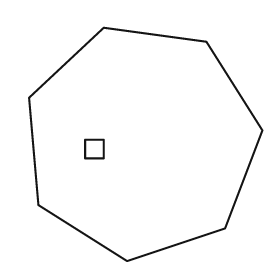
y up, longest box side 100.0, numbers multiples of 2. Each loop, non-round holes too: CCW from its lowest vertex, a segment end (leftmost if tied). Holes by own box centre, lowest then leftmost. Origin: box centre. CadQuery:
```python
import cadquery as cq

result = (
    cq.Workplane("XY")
    .moveTo(-8.0, -50.0)
    .lineTo(34.0, -36.0)
    .lineTo(50.0, 6.0)
    .lineTo(26.0, 44.0)
    .lineTo(-18.0, 50.0)
    .lineTo(-50.0, 20.0)
    .lineTo(-46.0, -26.0)
    .close()
    .moveTo(-26.0, -6.0)
    .lineTo(-18.0, -6.0)
    .lineTo(-18.0, 2.0)
    .lineTo(-26.0, 2.0)
    .close()
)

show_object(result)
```